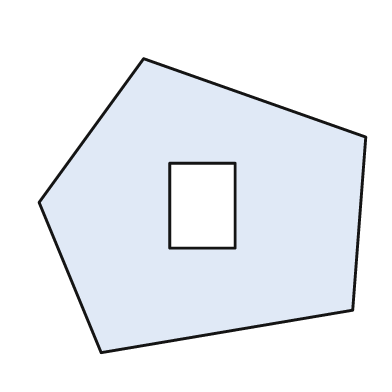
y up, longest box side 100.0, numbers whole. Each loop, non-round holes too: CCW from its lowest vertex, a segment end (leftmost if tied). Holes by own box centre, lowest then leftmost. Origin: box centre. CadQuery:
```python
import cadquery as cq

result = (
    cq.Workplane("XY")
    .moveTo(-31.0, -45.0)
    .lineTo(46.0, -32.0)
    .lineTo(50.0, 21.0)
    .lineTo(-18.0, 45.0)
    .lineTo(-50.0, 1.0)
    .close()
    .moveTo(-10.0, -13.0)
    .lineTo(10.0, -13.0)
    .lineTo(10.0, 13.0)
    .lineTo(-10.0, 13.0)
    .close()
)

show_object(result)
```